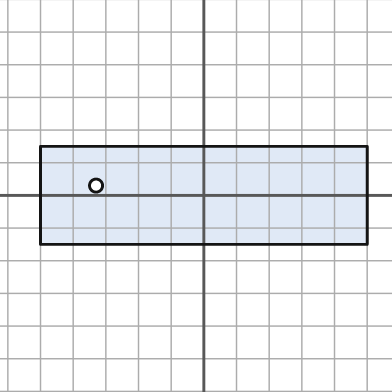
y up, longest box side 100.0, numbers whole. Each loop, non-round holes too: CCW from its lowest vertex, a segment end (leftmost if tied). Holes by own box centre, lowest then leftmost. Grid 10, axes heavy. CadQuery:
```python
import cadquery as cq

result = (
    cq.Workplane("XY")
    .moveTo(-50.0, -15.0)
    .lineTo(50.0, -15.0)
    .lineTo(50.0, 15.0)
    .lineTo(-50.0, 15.0)
    .close()
    .moveTo(-33.0, 3.0)
    .circle(2.0)
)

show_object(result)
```